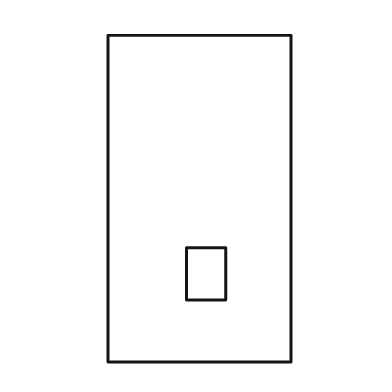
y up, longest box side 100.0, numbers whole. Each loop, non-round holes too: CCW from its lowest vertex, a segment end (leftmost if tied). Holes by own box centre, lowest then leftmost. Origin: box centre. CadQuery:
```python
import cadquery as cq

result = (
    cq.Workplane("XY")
    .moveTo(-28.0, -50.0)
    .lineTo(28.0, -50.0)
    .lineTo(28.0, 50.0)
    .lineTo(-28.0, 50.0)
    .close()
    .moveTo(-4.0, -31.0)
    .lineTo(8.0, -31.0)
    .lineTo(8.0, -15.0)
    .lineTo(-4.0, -15.0)
    .close()
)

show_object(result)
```